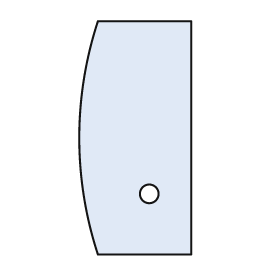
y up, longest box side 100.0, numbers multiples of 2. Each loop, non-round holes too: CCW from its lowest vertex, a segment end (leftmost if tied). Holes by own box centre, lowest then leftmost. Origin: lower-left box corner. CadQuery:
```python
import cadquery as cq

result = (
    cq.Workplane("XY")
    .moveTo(8.0, 0.0)
    .lineTo(48.0, 0.0)
    .lineTo(48.0, 100.0)
    .lineTo(8.0, 100.0)
    .threePointArc((0.0, 50.0), (8.0, 0.0))
    .close()
    .moveTo(30.0, 26.0)
    .circle(4.0)
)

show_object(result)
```